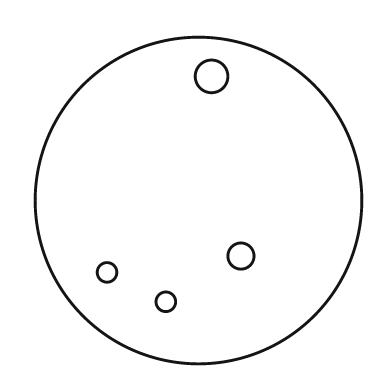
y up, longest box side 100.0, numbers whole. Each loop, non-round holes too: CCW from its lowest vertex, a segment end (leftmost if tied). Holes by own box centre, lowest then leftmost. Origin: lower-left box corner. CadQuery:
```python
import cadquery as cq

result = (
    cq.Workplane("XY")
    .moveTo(50.0, 50.0)
    .circle(50.0)
    .moveTo(40.0, 19.0)
    .circle(3.0)
    .moveTo(22.0, 28.0)
    .circle(3.0)
    .moveTo(63.0, 33.0)
    .circle(4.0)
    .moveTo(54.0, 88.0)
    .circle(5.0)
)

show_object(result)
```